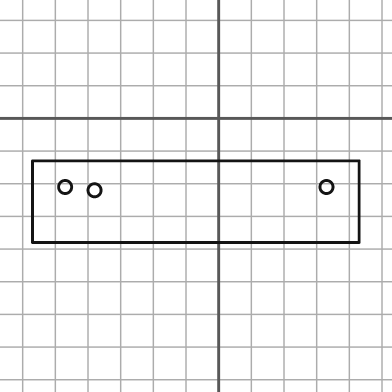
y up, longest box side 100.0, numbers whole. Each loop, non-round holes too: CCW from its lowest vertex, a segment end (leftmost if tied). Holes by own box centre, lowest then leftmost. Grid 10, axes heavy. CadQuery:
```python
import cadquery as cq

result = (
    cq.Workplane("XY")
    .moveTo(-57.0, -38.0)
    .lineTo(43.0, -38.0)
    .lineTo(43.0, -13.0)
    .lineTo(-57.0, -13.0)
    .close()
    .moveTo(-38.0, -22.0)
    .circle(2.0)
    .moveTo(-47.0, -21.0)
    .circle(2.0)
    .moveTo(33.0, -21.0)
    .circle(2.0)
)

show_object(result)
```